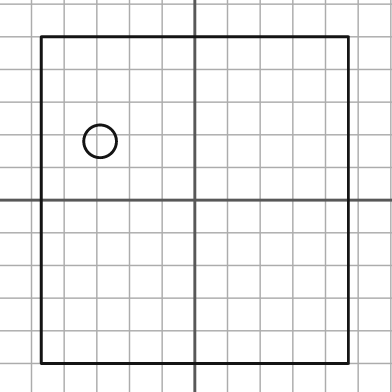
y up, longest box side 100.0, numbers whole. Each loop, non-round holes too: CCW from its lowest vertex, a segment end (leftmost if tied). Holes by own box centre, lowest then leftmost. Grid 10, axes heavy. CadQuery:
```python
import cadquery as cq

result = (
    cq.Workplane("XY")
    .moveTo(-47.0, -50.0)
    .lineTo(47.0, -50.0)
    .lineTo(47.0, 50.0)
    .lineTo(-47.0, 50.0)
    .close()
    .moveTo(-29.0, 18.0)
    .circle(5.0)
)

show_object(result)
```